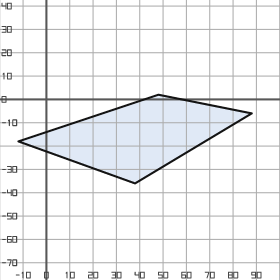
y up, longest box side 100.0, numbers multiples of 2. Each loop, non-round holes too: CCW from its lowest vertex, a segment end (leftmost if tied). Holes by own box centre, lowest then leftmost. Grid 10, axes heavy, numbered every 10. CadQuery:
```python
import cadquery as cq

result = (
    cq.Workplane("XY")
    .moveTo(38.0, -36.0)
    .lineTo(88.0, -6.0)
    .lineTo(48.0, 2.0)
    .lineTo(-12.0, -18.0)
    .close()
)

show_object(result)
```